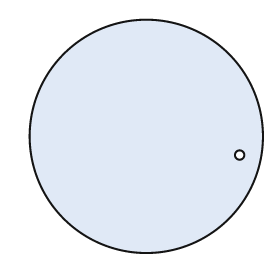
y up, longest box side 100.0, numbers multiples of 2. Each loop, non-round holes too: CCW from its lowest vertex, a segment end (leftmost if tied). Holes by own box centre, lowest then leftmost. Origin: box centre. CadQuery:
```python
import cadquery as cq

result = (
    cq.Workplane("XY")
    .moveTo(0.0, 0.0)
    .circle(50.0)
    .moveTo(40.0, -8.0)
    .circle(2.0)
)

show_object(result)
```